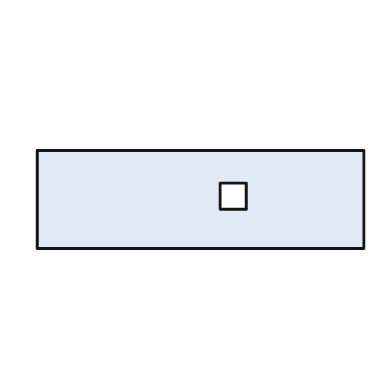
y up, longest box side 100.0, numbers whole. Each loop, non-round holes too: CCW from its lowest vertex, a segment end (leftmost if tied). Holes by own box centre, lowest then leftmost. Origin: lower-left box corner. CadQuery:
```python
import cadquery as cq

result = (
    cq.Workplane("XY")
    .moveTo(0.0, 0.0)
    .lineTo(100.0, 0.0)
    .lineTo(100.0, 30.0)
    .lineTo(0.0, 30.0)
    .close()
    .moveTo(56.0, 12.0)
    .lineTo(64.0, 12.0)
    .lineTo(64.0, 20.0)
    .lineTo(56.0, 20.0)
    .close()
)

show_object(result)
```